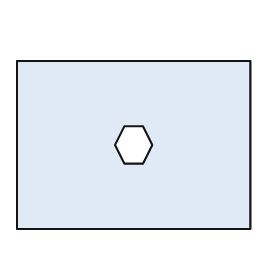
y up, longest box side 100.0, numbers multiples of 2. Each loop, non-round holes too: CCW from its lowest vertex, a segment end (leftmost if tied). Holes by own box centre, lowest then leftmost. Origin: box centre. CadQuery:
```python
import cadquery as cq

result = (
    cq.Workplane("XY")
    .moveTo(-50.0, -36.0)
    .lineTo(50.0, -36.0)
    .lineTo(50.0, 36.0)
    .lineTo(-50.0, 36.0)
    .close()
    .moveTo(-4.0, -8.0)
    .lineTo(4.0, -8.0)
    .lineTo(8.0, 0.0)
    .lineTo(4.0, 8.0)
    .lineTo(-4.0, 8.0)
    .lineTo(-8.0, 0.0)
    .close()
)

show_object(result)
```